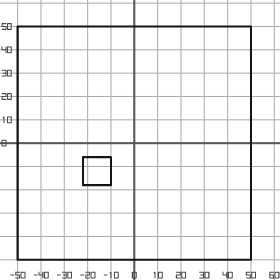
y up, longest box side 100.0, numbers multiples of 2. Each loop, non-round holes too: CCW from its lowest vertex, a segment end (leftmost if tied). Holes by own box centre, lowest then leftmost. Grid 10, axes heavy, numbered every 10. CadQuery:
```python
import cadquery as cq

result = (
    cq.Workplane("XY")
    .moveTo(-50.0, -50.0)
    .lineTo(50.0, -50.0)
    .lineTo(50.0, 50.0)
    .lineTo(-50.0, 50.0)
    .close()
    .moveTo(-22.0, -18.0)
    .lineTo(-10.0, -18.0)
    .lineTo(-10.0, -6.0)
    .lineTo(-22.0, -6.0)
    .close()
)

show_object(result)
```